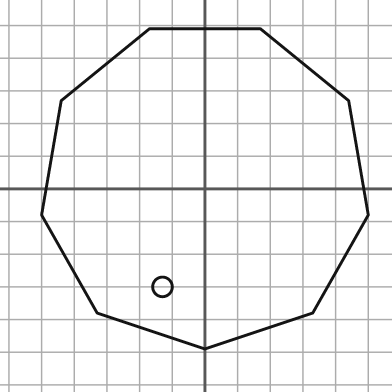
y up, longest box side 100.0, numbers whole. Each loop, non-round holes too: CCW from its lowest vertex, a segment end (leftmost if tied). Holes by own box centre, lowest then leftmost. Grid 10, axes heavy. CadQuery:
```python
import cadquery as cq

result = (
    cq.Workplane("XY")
    .moveTo(0.0, -49.0)
    .lineTo(33.0, -38.0)
    .lineTo(50.0, -8.0)
    .lineTo(44.0, 27.0)
    .lineTo(17.0, 49.0)
    .lineTo(-17.0, 49.0)
    .lineTo(-44.0, 27.0)
    .lineTo(-50.0, -8.0)
    .lineTo(-33.0, -38.0)
    .close()
    .moveTo(-13.0, -30.0)
    .circle(3.0)
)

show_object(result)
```